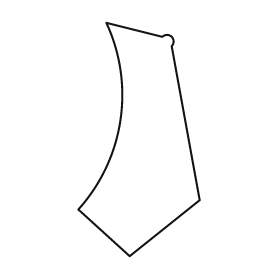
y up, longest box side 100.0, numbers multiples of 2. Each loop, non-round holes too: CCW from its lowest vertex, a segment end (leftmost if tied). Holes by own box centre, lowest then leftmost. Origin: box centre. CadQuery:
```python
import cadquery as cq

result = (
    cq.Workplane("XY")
    .moveTo(-4.0, -50.0)
    .lineTo(26.0, -26.0)
    .lineTo(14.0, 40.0)
    .threePointArc((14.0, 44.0), (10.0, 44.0))
    .lineTo(-14.0, 50.0)
    .threePointArc((-8.0, 8.0), (-26.0, -30.0))
    .close()
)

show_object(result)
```